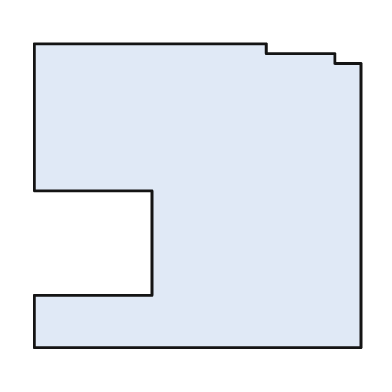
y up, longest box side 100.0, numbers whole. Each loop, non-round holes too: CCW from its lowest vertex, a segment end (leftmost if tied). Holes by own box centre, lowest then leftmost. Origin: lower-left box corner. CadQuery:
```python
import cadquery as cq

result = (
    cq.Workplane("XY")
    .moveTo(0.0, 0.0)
    .lineTo(100.0, 0.0)
    .lineTo(100.0, 87.0)
    .lineTo(92.0, 87.0)
    .lineTo(92.0, 90.0)
    .lineTo(71.0, 90.0)
    .lineTo(71.0, 93.0)
    .lineTo(0.0, 93.0)
    .lineTo(0.0, 48.0)
    .lineTo(36.0, 48.0)
    .lineTo(36.0, 16.0)
    .lineTo(0.0, 16.0)
    .close()
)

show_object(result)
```